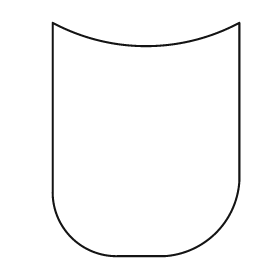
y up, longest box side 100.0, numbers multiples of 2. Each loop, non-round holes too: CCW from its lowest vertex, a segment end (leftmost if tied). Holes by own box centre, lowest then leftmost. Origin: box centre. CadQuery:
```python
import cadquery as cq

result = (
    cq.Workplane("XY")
    .moveTo(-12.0, -50.0)
    .lineTo(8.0, -50.0)
    .threePointArc((30.0, -40.0), (40.0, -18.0))
    .lineTo(40.0, 50.0)
    .threePointArc((0.0, 40.0), (-40.0, 50.0))
    .lineTo(-40.0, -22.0)
    .threePointArc((-32.0, -42.0), (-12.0, -50.0))
    .close()
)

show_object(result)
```